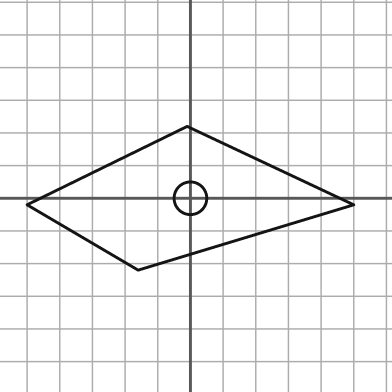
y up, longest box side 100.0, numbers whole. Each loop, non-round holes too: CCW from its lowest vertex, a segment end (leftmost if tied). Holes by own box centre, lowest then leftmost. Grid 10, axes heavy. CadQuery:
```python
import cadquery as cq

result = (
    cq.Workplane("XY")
    .moveTo(-16.0, -22.0)
    .lineTo(50.0, -2.0)
    .lineTo(-1.0, 22.0)
    .lineTo(-50.0, -2.0)
    .close()
    .moveTo(0.0, 0.0)
    .circle(5.0)
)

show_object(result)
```